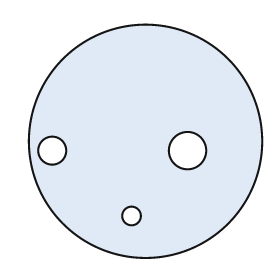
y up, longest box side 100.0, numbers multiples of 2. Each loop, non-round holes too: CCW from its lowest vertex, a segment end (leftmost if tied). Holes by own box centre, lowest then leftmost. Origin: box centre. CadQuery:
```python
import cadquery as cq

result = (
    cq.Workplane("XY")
    .moveTo(0.0, 0.0)
    .circle(50.0)
    .moveTo(-6.0, -32.0)
    .circle(4.0)
    .moveTo(-40.0, -4.0)
    .circle(6.0)
    .moveTo(18.0, -4.0)
    .circle(8.0)
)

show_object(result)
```